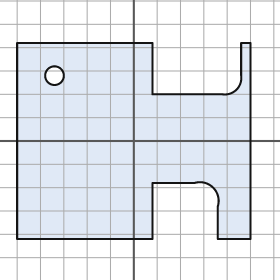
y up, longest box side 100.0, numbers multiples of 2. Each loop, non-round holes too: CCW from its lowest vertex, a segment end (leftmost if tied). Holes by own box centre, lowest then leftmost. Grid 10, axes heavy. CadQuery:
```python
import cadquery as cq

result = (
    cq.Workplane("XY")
    .moveTo(-50.0, -42.0)
    .lineTo(8.0, -42.0)
    .lineTo(8.0, -18.0)
    .lineTo(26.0, -18.0)
    .threePointArc((34.0, -20.0), (36.0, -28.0))
    .lineTo(36.0, -42.0)
    .lineTo(50.0, -42.0)
    .lineTo(50.0, 42.0)
    .lineTo(46.0, 42.0)
    .lineTo(46.0, 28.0)
    .threePointArc((44.0, 22.0), (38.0, 20.0))
    .lineTo(8.0, 20.0)
    .lineTo(8.0, 42.0)
    .lineTo(-50.0, 42.0)
    .close()
    .moveTo(-34.0, 28.0)
    .circle(4.0)
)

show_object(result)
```